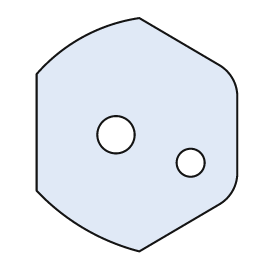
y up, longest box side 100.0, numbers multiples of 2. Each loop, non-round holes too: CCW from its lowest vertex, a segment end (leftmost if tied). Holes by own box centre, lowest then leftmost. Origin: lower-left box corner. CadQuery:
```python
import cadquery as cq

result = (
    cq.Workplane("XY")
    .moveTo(44.0, 0.0)
    .lineTo(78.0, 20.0)
    .threePointArc((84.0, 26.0), (86.0, 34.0))
    .lineTo(86.0, 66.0)
    .threePointArc((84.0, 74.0), (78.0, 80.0))
    .lineTo(44.0, 100.0)
    .threePointArc((20.0, 92.0), (0.0, 76.0))
    .lineTo(0.0, 26.0)
    .threePointArc((20.0, 10.0), (44.0, 0.0))
    .close()
    .moveTo(66.0, 38.0)
    .circle(6.0)
    .moveTo(34.0, 50.0)
    .circle(8.0)
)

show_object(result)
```